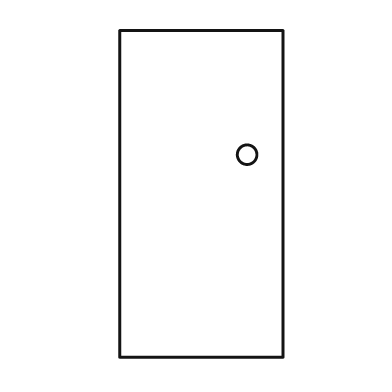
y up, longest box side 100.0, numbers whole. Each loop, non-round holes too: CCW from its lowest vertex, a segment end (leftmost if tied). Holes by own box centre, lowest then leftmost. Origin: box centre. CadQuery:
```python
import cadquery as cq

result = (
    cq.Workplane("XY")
    .moveTo(-25.0, -50.0)
    .lineTo(25.0, -50.0)
    .lineTo(25.0, 50.0)
    .lineTo(-25.0, 50.0)
    .close()
    .moveTo(14.0, 12.0)
    .circle(3.0)
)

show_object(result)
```